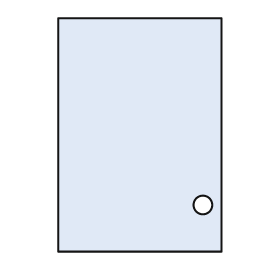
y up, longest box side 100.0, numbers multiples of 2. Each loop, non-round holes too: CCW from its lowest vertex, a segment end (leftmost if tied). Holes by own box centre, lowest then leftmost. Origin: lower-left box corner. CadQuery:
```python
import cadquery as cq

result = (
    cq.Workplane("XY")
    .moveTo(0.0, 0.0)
    .lineTo(70.0, 0.0)
    .lineTo(70.0, 100.0)
    .lineTo(0.0, 100.0)
    .close()
    .moveTo(62.0, 20.0)
    .circle(4.0)
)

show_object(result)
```